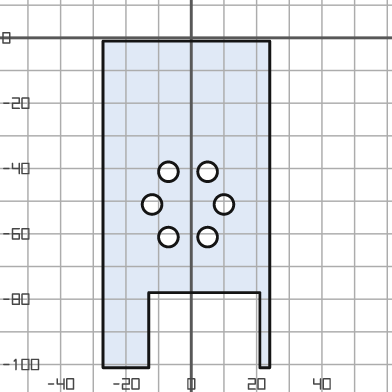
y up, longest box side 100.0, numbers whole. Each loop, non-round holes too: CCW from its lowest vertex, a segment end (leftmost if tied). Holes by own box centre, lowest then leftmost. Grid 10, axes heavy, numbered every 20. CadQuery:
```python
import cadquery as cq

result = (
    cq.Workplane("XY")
    .moveTo(-27.0, -101.0)
    .lineTo(-13.0, -101.0)
    .lineTo(-13.0, -78.0)
    .lineTo(21.0, -78.0)
    .lineTo(21.0, -101.0)
    .lineTo(24.0, -101.0)
    .lineTo(24.0, -1.0)
    .lineTo(-27.0, -1.0)
    .close()
    .moveTo(-7.0, -61.0)
    .circle(3.0)
    .moveTo(5.0, -61.0)
    .circle(3.0)
    .moveTo(-12.0, -51.0)
    .circle(3.0)
    .moveTo(10.0, -51.0)
    .circle(3.0)
    .moveTo(-7.0, -41.0)
    .circle(3.0)
    .moveTo(5.0, -41.0)
    .circle(3.0)
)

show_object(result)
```